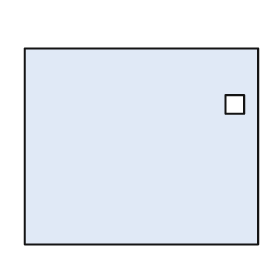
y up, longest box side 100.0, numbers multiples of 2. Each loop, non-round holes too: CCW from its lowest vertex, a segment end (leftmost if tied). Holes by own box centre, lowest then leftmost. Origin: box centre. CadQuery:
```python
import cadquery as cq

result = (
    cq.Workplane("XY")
    .moveTo(-50.0, -42.0)
    .lineTo(50.0, -42.0)
    .lineTo(50.0, 42.0)
    .lineTo(-50.0, 42.0)
    .close()
    .moveTo(36.0, 14.0)
    .lineTo(44.0, 14.0)
    .lineTo(44.0, 22.0)
    .lineTo(36.0, 22.0)
    .close()
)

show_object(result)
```